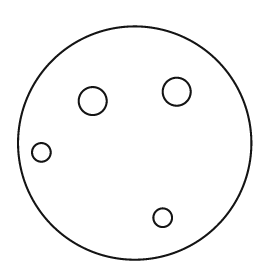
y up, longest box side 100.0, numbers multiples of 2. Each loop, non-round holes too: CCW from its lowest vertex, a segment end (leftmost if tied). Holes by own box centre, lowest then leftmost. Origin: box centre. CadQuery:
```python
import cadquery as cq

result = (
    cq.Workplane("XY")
    .moveTo(0.0, 0.0)
    .circle(50.0)
    .moveTo(12.0, -32.0)
    .circle(4.0)
    .moveTo(-40.0, -4.0)
    .circle(4.0)
    .moveTo(-18.0, 18.0)
    .circle(6.0)
    .moveTo(18.0, 22.0)
    .circle(6.0)
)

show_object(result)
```